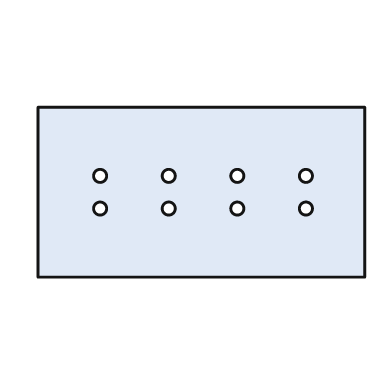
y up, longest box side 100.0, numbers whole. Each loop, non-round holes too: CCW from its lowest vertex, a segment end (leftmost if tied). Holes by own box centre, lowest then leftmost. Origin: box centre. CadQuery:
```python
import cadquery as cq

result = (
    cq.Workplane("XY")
    .moveTo(-50.0, -26.0)
    .lineTo(50.0, -26.0)
    .lineTo(50.0, 26.0)
    .lineTo(-50.0, 26.0)
    .close()
    .moveTo(-31.0, -5.0)
    .circle(2.0)
    .moveTo(-10.0, -5.0)
    .circle(2.0)
    .moveTo(11.0, -5.0)
    .circle(2.0)
    .moveTo(32.0, -5.0)
    .circle(2.0)
    .moveTo(-31.0, 5.0)
    .circle(2.0)
    .moveTo(-10.0, 5.0)
    .circle(2.0)
    .moveTo(11.0, 5.0)
    .circle(2.0)
    .moveTo(32.0, 5.0)
    .circle(2.0)
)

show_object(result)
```